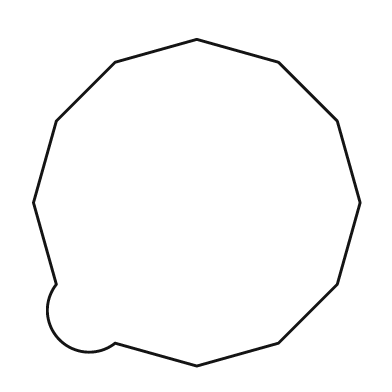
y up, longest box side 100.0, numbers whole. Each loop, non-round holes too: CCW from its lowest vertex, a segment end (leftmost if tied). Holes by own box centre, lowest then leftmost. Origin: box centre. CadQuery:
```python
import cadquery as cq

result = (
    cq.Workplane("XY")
    .moveTo(0.0, -50.0)
    .lineTo(25.0, -43.0)
    .lineTo(43.0, -25.0)
    .lineTo(50.0, 0.0)
    .lineTo(43.0, 25.0)
    .lineTo(25.0, 43.0)
    .lineTo(0.0, 50.0)
    .lineTo(-25.0, 43.0)
    .lineTo(-43.0, 25.0)
    .lineTo(-50.0, 0.0)
    .lineTo(-43.0, -25.0)
    .threePointArc((-42.0, -42.0), (-25.0, -43.0))
    .close()
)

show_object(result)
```